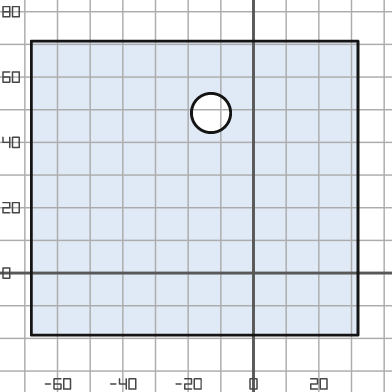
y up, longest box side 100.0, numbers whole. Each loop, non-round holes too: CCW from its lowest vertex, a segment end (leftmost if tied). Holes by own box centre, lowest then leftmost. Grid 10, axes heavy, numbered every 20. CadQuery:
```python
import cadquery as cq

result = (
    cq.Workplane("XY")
    .moveTo(-68.0, -19.0)
    .lineTo(32.0, -19.0)
    .lineTo(32.0, 71.0)
    .lineTo(-68.0, 71.0)
    .close()
    .moveTo(-13.0, 49.0)
    .circle(6.0)
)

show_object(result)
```